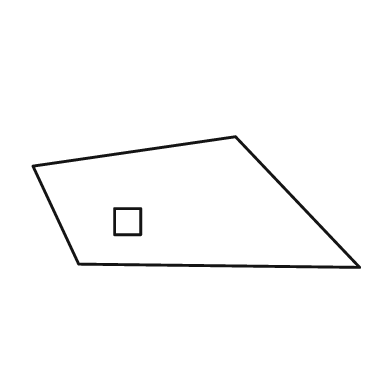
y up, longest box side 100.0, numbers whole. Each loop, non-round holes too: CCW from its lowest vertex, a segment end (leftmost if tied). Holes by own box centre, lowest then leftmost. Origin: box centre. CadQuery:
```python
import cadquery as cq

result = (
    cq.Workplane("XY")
    .moveTo(50.0, -20.0)
    .lineTo(12.0, 20.0)
    .lineTo(-50.0, 11.0)
    .lineTo(-36.0, -19.0)
    .close()
    .moveTo(-25.0, -10.0)
    .lineTo(-17.0, -10.0)
    .lineTo(-17.0, -2.0)
    .lineTo(-25.0, -2.0)
    .close()
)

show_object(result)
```